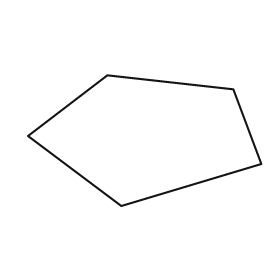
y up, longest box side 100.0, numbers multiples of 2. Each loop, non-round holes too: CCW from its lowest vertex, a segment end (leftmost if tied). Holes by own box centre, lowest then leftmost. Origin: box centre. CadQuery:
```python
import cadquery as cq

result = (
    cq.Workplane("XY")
    .moveTo(-10.0, -28.0)
    .lineTo(50.0, -10.0)
    .lineTo(38.0, 22.0)
    .lineTo(-16.0, 28.0)
    .lineTo(-50.0, 2.0)
    .close()
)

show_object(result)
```